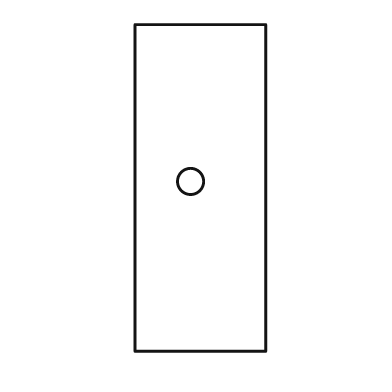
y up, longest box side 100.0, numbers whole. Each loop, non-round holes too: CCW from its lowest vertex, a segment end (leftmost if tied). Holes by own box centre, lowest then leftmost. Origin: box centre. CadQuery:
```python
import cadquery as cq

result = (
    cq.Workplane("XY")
    .moveTo(-20.0, -50.0)
    .lineTo(20.0, -50.0)
    .lineTo(20.0, 50.0)
    .lineTo(-20.0, 50.0)
    .close()
    .moveTo(-3.0, 2.0)
    .circle(4.0)
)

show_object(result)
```